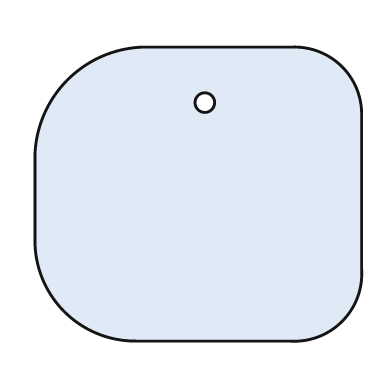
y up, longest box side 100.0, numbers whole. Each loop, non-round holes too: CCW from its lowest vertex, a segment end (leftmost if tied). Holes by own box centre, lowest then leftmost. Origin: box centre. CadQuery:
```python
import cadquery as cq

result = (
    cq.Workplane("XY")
    .moveTo(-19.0, -45.0)
    .lineTo(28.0, -45.0)
    .threePointArc((44.0, -39.0), (50.0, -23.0))
    .lineTo(50.0, 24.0)
    .threePointArc((44.0, 39.0), (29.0, 45.0))
    .lineTo(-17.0, 45.0)
    .threePointArc((-40.0, 35.0), (-50.0, 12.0))
    .lineTo(-50.0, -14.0)
    .threePointArc((-41.0, -36.0), (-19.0, -45.0))
    .close()
    .moveTo(2.0, 28.0)
    .circle(3.0)
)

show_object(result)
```